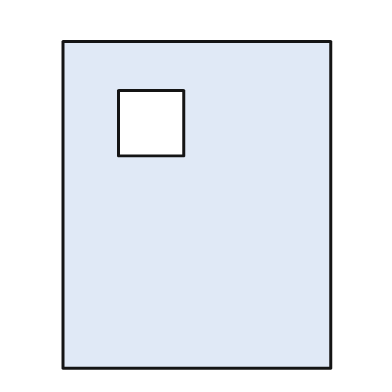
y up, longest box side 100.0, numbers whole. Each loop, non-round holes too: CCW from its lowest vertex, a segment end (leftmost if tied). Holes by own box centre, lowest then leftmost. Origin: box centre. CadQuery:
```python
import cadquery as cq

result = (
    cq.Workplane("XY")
    .moveTo(-41.0, -50.0)
    .lineTo(41.0, -50.0)
    .lineTo(41.0, 50.0)
    .lineTo(-41.0, 50.0)
    .close()
    .moveTo(-24.0, 15.0)
    .lineTo(-4.0, 15.0)
    .lineTo(-4.0, 35.0)
    .lineTo(-24.0, 35.0)
    .close()
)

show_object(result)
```